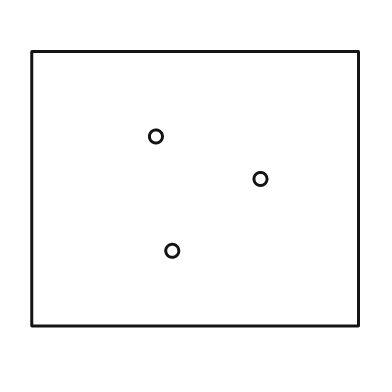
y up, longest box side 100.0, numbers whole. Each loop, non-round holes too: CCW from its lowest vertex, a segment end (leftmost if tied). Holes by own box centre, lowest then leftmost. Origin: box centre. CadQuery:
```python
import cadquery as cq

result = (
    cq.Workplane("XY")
    .moveTo(-50.0, -42.0)
    .lineTo(50.0, -42.0)
    .lineTo(50.0, 42.0)
    .lineTo(-50.0, 42.0)
    .close()
    .moveTo(-7.0, -19.0)
    .circle(2.0)
    .moveTo(20.0, 3.0)
    .circle(2.0)
    .moveTo(-12.0, 16.0)
    .circle(2.0)
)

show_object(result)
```